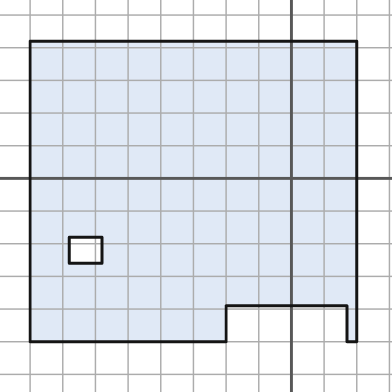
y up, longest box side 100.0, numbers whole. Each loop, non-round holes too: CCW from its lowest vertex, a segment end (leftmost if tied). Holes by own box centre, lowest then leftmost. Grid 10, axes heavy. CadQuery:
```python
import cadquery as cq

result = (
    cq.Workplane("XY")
    .moveTo(-80.0, -50.0)
    .lineTo(-20.0, -50.0)
    .lineTo(-20.0, -39.0)
    .lineTo(17.0, -39.0)
    .lineTo(17.0, -50.0)
    .lineTo(20.0, -50.0)
    .lineTo(20.0, 42.0)
    .lineTo(-80.0, 42.0)
    .close()
    .moveTo(-68.0, -26.0)
    .lineTo(-58.0, -26.0)
    .lineTo(-58.0, -18.0)
    .lineTo(-68.0, -18.0)
    .close()
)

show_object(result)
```